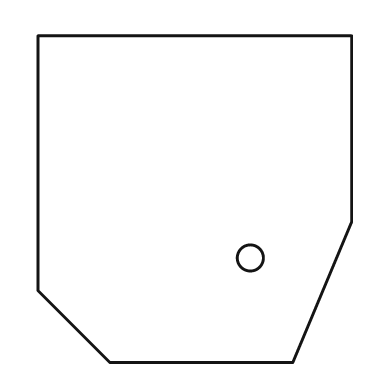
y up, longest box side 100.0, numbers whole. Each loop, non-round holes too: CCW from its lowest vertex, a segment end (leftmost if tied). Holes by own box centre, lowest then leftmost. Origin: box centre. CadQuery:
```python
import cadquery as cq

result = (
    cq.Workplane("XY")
    .moveTo(-26.0, -50.0)
    .lineTo(30.0, -50.0)
    .lineTo(48.0, -7.0)
    .lineTo(48.0, 50.0)
    .lineTo(-48.0, 50.0)
    .lineTo(-48.0, -28.0)
    .close()
    .moveTo(17.0, -18.0)
    .circle(4.0)
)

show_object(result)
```